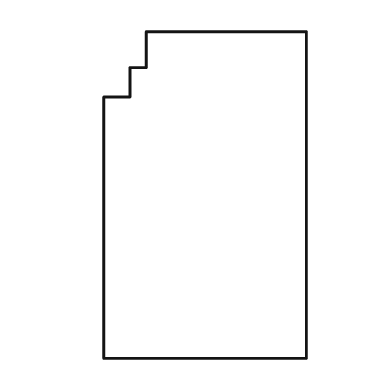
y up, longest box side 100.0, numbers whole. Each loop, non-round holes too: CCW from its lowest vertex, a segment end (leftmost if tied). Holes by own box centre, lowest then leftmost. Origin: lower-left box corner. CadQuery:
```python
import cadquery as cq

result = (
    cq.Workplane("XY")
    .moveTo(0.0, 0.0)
    .lineTo(62.0, 0.0)
    .lineTo(62.0, 100.0)
    .lineTo(13.0, 100.0)
    .lineTo(13.0, 89.0)
    .lineTo(8.0, 89.0)
    .lineTo(8.0, 80.0)
    .lineTo(0.0, 80.0)
    .close()
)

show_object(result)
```